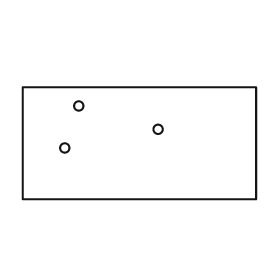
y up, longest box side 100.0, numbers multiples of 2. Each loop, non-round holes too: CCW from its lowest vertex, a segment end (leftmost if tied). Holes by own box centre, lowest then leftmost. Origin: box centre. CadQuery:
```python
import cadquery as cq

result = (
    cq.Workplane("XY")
    .moveTo(-50.0, -24.0)
    .lineTo(50.0, -24.0)
    .lineTo(50.0, 24.0)
    .lineTo(-50.0, 24.0)
    .close()
    .moveTo(-32.0, -2.0)
    .circle(2.0)
    .moveTo(8.0, 6.0)
    .circle(2.0)
    .moveTo(-26.0, 16.0)
    .circle(2.0)
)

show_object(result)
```